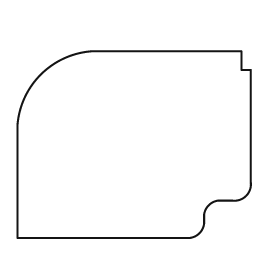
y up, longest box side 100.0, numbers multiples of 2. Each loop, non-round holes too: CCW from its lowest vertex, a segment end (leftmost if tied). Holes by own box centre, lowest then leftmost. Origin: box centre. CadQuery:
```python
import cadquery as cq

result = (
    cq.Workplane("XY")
    .moveTo(-50.0, -40.0)
    .lineTo(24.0, -40.0)
    .threePointArc((28.0, -38.0), (30.0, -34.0))
    .lineTo(30.0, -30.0)
    .threePointArc((32.0, -26.0), (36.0, -24.0))
    .lineTo(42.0, -24.0)
    .threePointArc((48.0, -22.0), (50.0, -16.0))
    .lineTo(50.0, 32.0)
    .lineTo(46.0, 32.0)
    .lineTo(46.0, 40.0)
    .lineTo(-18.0, 40.0)
    .threePointArc((-40.0, 30.0), (-50.0, 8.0))
    .close()
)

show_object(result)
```